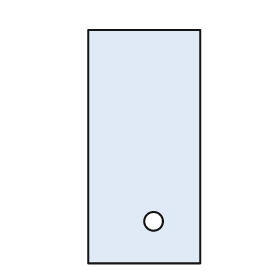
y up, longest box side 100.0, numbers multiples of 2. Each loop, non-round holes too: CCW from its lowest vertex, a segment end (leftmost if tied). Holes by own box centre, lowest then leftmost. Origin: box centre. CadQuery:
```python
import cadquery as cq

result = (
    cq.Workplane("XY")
    .moveTo(-24.0, -50.0)
    .lineTo(24.0, -50.0)
    .lineTo(24.0, 50.0)
    .lineTo(-24.0, 50.0)
    .close()
    .moveTo(4.0, -32.0)
    .circle(4.0)
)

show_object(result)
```